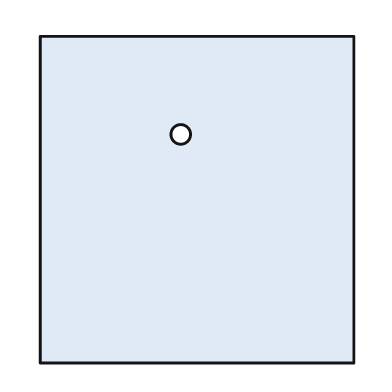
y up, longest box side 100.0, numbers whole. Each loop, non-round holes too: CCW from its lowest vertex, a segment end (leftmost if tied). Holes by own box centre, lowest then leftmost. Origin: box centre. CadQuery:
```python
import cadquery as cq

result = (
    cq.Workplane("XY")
    .moveTo(-48.0, -50.0)
    .lineTo(48.0, -50.0)
    .lineTo(48.0, 50.0)
    .lineTo(-48.0, 50.0)
    .close()
    .moveTo(-5.0, 20.0)
    .circle(3.0)
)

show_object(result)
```